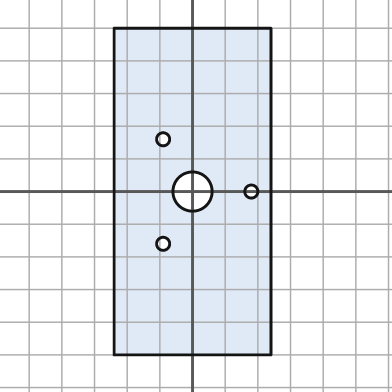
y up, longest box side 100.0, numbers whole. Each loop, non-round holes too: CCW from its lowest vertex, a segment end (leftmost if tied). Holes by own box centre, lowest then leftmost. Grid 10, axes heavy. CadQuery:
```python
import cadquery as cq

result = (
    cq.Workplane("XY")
    .moveTo(-24.0, -50.0)
    .lineTo(24.0, -50.0)
    .lineTo(24.0, 50.0)
    .lineTo(-24.0, 50.0)
    .close()
    .moveTo(-9.0, -16.0)
    .circle(2.0)
    .moveTo(0.0, 0.0)
    .circle(6.0)
    .moveTo(18.0, 0.0)
    .circle(2.0)
    .moveTo(-9.0, 16.0)
    .circle(2.0)
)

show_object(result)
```